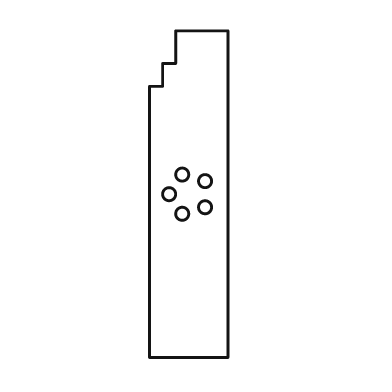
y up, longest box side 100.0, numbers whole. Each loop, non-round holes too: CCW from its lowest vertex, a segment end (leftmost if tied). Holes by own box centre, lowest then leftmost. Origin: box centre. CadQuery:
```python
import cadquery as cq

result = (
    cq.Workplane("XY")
    .moveTo(-12.0, -50.0)
    .lineTo(12.0, -50.0)
    .lineTo(12.0, 50.0)
    .lineTo(-4.0, 50.0)
    .lineTo(-4.0, 40.0)
    .lineTo(-8.0, 40.0)
    .lineTo(-8.0, 33.0)
    .lineTo(-12.0, 33.0)
    .close()
    .moveTo(-2.0, -6.0)
    .circle(2.0)
    .moveTo(5.0, -4.0)
    .circle(2.0)
    .moveTo(-6.0, 0.0)
    .circle(2.0)
    .moveTo(5.0, 4.0)
    .circle(2.0)
    .moveTo(-2.0, 6.0)
    .circle(2.0)
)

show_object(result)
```